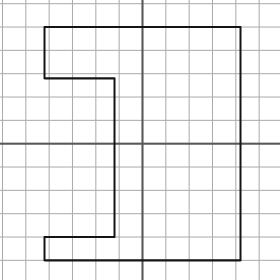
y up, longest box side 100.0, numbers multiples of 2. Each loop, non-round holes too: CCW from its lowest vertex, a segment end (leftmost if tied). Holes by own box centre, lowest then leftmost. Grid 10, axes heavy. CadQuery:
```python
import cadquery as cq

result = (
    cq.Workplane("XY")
    .moveTo(-42.0, -50.0)
    .lineTo(42.0, -50.0)
    .lineTo(42.0, 50.0)
    .lineTo(-42.0, 50.0)
    .lineTo(-42.0, 28.0)
    .lineTo(-12.0, 28.0)
    .lineTo(-12.0, -40.0)
    .lineTo(-42.0, -40.0)
    .close()
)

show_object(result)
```